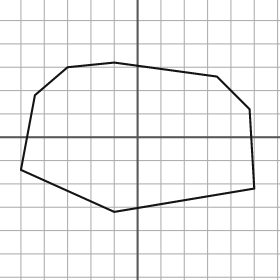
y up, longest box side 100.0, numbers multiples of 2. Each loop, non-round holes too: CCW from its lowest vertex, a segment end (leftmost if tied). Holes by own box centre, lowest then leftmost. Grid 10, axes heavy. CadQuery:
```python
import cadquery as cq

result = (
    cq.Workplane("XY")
    .moveTo(-10.0, -32.0)
    .lineTo(50.0, -22.0)
    .lineTo(48.0, 12.0)
    .lineTo(34.0, 26.0)
    .lineTo(-10.0, 32.0)
    .lineTo(-30.0, 30.0)
    .lineTo(-44.0, 18.0)
    .lineTo(-50.0, -14.0)
    .close()
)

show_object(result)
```